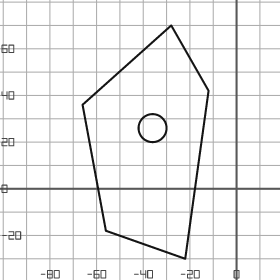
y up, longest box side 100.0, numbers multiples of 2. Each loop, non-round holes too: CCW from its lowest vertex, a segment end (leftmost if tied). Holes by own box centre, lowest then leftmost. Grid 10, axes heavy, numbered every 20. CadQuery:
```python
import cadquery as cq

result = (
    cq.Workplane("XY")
    .moveTo(-22.0, -30.0)
    .lineTo(-12.0, 42.0)
    .lineTo(-28.0, 70.0)
    .lineTo(-66.0, 36.0)
    .lineTo(-56.0, -18.0)
    .close()
    .moveTo(-36.0, 26.0)
    .circle(6.0)
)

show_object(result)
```